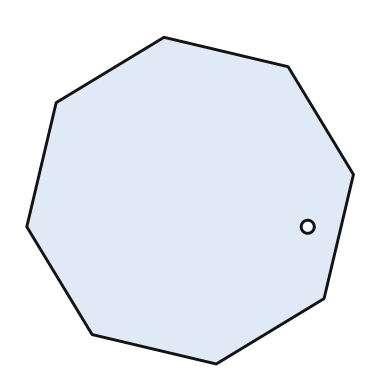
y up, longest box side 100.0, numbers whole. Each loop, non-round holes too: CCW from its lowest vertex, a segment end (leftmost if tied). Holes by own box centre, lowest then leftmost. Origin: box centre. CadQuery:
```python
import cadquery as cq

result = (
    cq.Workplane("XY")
    .moveTo(8.0, -50.0)
    .lineTo(41.0, -30.0)
    .lineTo(50.0, 8.0)
    .lineTo(30.0, 41.0)
    .lineTo(-8.0, 50.0)
    .lineTo(-41.0, 30.0)
    .lineTo(-50.0, -8.0)
    .lineTo(-30.0, -41.0)
    .close()
    .moveTo(36.0, -8.0)
    .circle(2.0)
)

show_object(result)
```